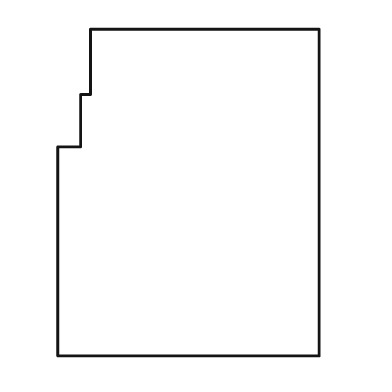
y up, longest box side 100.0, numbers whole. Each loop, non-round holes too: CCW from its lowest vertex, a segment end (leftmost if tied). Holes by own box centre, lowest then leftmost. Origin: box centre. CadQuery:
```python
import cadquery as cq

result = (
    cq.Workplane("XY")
    .moveTo(-40.0, -50.0)
    .lineTo(40.0, -50.0)
    .lineTo(40.0, 50.0)
    .lineTo(-30.0, 50.0)
    .lineTo(-30.0, 30.0)
    .lineTo(-33.0, 30.0)
    .lineTo(-33.0, 14.0)
    .lineTo(-40.0, 14.0)
    .close()
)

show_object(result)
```